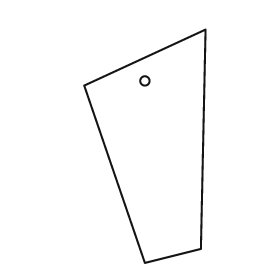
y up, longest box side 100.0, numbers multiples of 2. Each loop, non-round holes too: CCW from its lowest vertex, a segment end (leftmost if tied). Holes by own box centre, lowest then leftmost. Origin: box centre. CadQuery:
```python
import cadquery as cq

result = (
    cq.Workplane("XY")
    .moveTo(0.0, -50.0)
    .lineTo(24.0, -44.0)
    .lineTo(26.0, 50.0)
    .lineTo(-26.0, 26.0)
    .close()
    .moveTo(0.0, 28.0)
    .circle(2.0)
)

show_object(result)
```